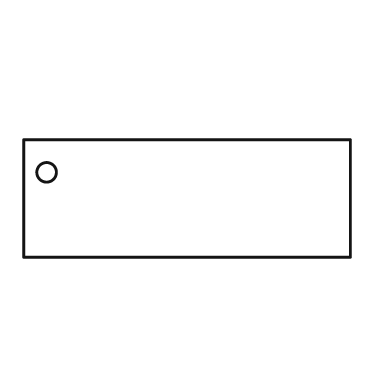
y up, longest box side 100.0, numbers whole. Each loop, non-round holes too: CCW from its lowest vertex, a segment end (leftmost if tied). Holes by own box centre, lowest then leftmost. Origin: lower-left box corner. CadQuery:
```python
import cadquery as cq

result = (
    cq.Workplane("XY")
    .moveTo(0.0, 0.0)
    .lineTo(100.0, 0.0)
    .lineTo(100.0, 36.0)
    .lineTo(0.0, 36.0)
    .close()
    .moveTo(7.0, 26.0)
    .circle(3.0)
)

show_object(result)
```